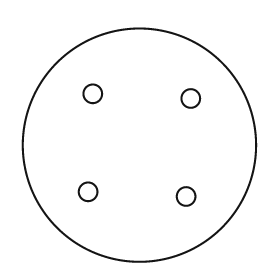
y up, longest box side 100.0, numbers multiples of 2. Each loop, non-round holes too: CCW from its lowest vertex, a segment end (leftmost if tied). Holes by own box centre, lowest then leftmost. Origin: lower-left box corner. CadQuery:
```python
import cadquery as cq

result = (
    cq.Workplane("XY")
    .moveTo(50.0, 50.0)
    .circle(50.0)
    .moveTo(70.0, 28.0)
    .circle(4.0)
    .moveTo(28.0, 30.0)
    .circle(4.0)
    .moveTo(72.0, 70.0)
    .circle(4.0)
    .moveTo(30.0, 72.0)
    .circle(4.0)
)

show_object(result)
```